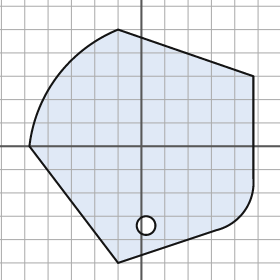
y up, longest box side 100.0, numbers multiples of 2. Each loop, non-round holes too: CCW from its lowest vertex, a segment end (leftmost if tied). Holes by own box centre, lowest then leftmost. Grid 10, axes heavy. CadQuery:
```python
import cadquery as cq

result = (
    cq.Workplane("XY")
    .moveTo(-10.0, -50.0)
    .lineTo(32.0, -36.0)
    .threePointArc((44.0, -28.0), (48.0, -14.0))
    .lineTo(48.0, 30.0)
    .lineTo(-10.0, 50.0)
    .threePointArc((-36.0, 30.0), (-48.0, 0.0))
    .close()
    .moveTo(2.0, -34.0)
    .circle(4.0)
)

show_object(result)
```